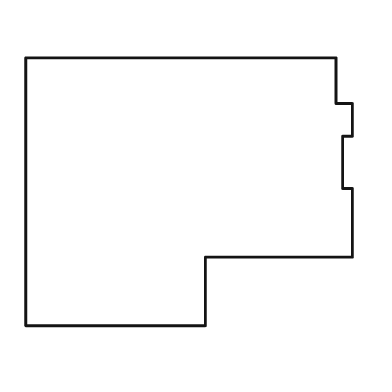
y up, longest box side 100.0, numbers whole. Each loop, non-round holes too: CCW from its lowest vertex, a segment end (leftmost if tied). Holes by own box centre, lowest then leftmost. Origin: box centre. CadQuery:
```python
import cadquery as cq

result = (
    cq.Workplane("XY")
    .moveTo(-50.0, -41.0)
    .lineTo(5.0, -41.0)
    .lineTo(5.0, -20.0)
    .lineTo(50.0, -20.0)
    .lineTo(50.0, 1.0)
    .lineTo(47.0, 1.0)
    .lineTo(47.0, 17.0)
    .lineTo(50.0, 17.0)
    .lineTo(50.0, 27.0)
    .lineTo(45.0, 27.0)
    .lineTo(45.0, 41.0)
    .lineTo(-50.0, 41.0)
    .close()
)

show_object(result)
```